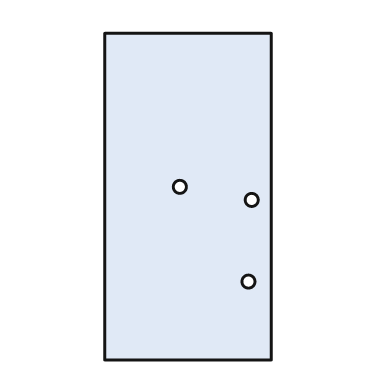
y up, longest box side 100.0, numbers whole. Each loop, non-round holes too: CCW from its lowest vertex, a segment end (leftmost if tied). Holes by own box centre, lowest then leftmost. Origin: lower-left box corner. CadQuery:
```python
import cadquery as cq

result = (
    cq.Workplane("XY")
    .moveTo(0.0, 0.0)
    .lineTo(51.0, 0.0)
    .lineTo(51.0, 100.0)
    .lineTo(0.0, 100.0)
    .close()
    .moveTo(44.0, 24.0)
    .circle(2.0)
    .moveTo(45.0, 49.0)
    .circle(2.0)
    .moveTo(23.0, 53.0)
    .circle(2.0)
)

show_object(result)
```